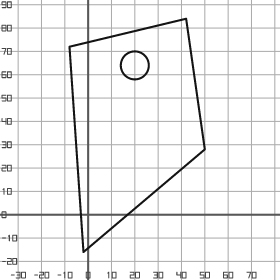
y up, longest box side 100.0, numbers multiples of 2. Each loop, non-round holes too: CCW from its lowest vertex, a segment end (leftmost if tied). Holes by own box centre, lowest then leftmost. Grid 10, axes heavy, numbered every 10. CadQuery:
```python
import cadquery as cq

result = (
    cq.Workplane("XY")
    .moveTo(-2.0, -16.0)
    .lineTo(50.0, 28.0)
    .lineTo(42.0, 84.0)
    .lineTo(-8.0, 72.0)
    .close()
    .moveTo(20.0, 64.0)
    .circle(6.0)
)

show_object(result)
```